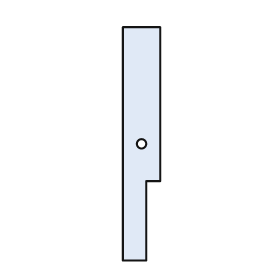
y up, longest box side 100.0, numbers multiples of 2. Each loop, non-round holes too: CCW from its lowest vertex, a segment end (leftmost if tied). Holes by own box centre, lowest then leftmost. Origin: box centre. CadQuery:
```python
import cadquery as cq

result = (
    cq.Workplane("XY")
    .moveTo(-8.0, -50.0)
    .lineTo(2.0, -50.0)
    .lineTo(2.0, -16.0)
    .lineTo(8.0, -16.0)
    .lineTo(8.0, 50.0)
    .lineTo(-8.0, 50.0)
    .close()
    .moveTo(0.0, 0.0)
    .circle(2.0)
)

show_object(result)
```